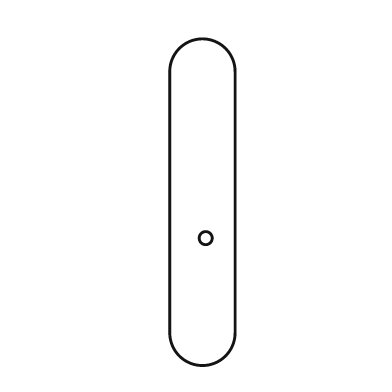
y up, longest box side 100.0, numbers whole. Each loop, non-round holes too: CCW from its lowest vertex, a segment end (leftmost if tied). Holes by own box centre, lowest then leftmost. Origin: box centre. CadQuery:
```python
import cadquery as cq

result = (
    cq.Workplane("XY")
    .moveTo(-10.0, -40.0)
    .threePointArc((0.0, -50.0), (10.0, -40.0))
    .lineTo(10.0, 40.0)
    .threePointArc((0.0, 50.0), (-10.0, 40.0))
    .close()
    .moveTo(1.0, -11.0)
    .circle(2.0)
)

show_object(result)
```